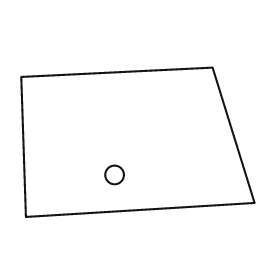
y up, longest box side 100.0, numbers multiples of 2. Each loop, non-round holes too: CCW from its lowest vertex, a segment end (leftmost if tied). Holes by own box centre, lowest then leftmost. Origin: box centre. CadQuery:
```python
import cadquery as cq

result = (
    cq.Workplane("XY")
    .moveTo(-48.0, -32.0)
    .lineTo(50.0, -26.0)
    .lineTo(32.0, 32.0)
    .lineTo(-50.0, 28.0)
    .close()
    .moveTo(-10.0, -14.0)
    .circle(4.0)
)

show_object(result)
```